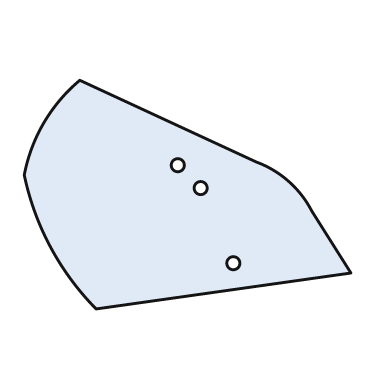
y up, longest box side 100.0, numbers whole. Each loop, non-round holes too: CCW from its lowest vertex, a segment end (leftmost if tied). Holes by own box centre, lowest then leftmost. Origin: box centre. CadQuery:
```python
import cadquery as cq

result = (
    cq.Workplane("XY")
    .moveTo(-28.0, -35.0)
    .lineTo(50.0, -24.0)
    .lineTo(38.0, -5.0)
    .threePointArc((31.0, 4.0), (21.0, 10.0))
    .lineTo(-33.0, 35.0)
    .threePointArc((-44.0, 22.0), (-50.0, 6.0))
    .threePointArc((-42.0, -16.0), (-28.0, -35.0))
    .close()
    .moveTo(14.0, -21.0)
    .circle(2.0)
    .moveTo(4.0, 2.0)
    .circle(2.0)
    .moveTo(-3.0, 9.0)
    .circle(2.0)
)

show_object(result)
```